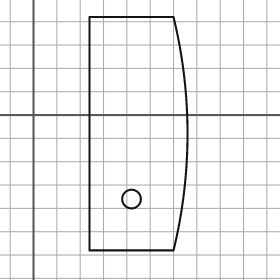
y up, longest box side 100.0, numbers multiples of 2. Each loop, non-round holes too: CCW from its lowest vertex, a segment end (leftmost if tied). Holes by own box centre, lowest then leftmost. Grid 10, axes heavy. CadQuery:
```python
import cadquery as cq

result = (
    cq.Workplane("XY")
    .moveTo(24.0, -58.0)
    .lineTo(60.0, -58.0)
    .threePointArc((66.0, -8.0), (60.0, 42.0))
    .lineTo(24.0, 42.0)
    .close()
    .moveTo(42.0, -36.0)
    .circle(4.0)
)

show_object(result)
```